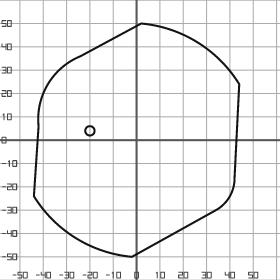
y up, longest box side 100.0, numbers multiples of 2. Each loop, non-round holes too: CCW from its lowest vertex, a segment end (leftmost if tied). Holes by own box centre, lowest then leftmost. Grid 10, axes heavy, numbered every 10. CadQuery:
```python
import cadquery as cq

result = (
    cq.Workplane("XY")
    .moveTo(-2.0, -50.0)
    .lineTo(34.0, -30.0)
    .threePointArc((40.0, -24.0), (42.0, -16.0))
    .lineTo(44.0, 24.0)
    .threePointArc((26.0, 42.0), (2.0, 50.0))
    .lineTo(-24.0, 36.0)
    .threePointArc((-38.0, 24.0), (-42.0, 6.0))
    .lineTo(-44.0, -24.0)
    .threePointArc((-26.0, -42.0), (-2.0, -50.0))
    .close()
    .moveTo(-20.0, 4.0)
    .circle(2.0)
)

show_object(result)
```